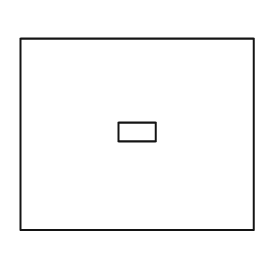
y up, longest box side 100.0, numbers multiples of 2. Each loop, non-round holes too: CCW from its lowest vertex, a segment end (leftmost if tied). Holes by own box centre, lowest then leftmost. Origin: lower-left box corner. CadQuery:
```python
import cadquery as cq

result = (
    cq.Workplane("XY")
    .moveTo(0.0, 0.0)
    .lineTo(100.0, 0.0)
    .lineTo(100.0, 82.0)
    .lineTo(0.0, 82.0)
    .close()
    .moveTo(42.0, 38.0)
    .lineTo(58.0, 38.0)
    .lineTo(58.0, 46.0)
    .lineTo(42.0, 46.0)
    .close()
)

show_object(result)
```